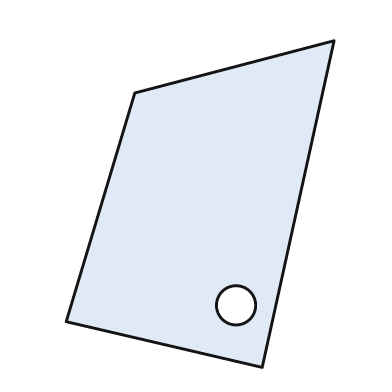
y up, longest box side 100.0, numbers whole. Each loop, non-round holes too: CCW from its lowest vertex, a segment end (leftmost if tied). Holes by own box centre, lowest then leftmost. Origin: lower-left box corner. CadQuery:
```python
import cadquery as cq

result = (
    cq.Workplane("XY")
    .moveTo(60.0, 0.0)
    .lineTo(82.0, 100.0)
    .lineTo(21.0, 84.0)
    .lineTo(0.0, 14.0)
    .close()
    .moveTo(52.0, 19.0)
    .circle(6.0)
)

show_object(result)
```